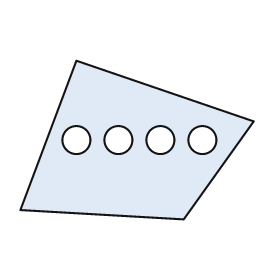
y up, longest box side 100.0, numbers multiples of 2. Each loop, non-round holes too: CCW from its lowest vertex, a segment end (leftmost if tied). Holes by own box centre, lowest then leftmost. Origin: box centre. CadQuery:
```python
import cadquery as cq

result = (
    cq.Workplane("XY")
    .moveTo(20.0, -34.0)
    .lineTo(50.0, 8.0)
    .lineTo(-26.0, 34.0)
    .lineTo(-50.0, -30.0)
    .close()
    .moveTo(-26.0, 0.0)
    .circle(6.0)
    .moveTo(-8.0, 0.0)
    .circle(6.0)
    .moveTo(10.0, 0.0)
    .circle(6.0)
    .moveTo(28.0, 0.0)
    .circle(6.0)
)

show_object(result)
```